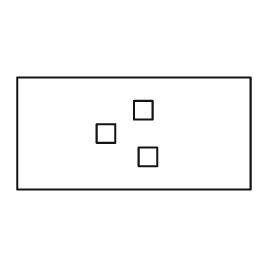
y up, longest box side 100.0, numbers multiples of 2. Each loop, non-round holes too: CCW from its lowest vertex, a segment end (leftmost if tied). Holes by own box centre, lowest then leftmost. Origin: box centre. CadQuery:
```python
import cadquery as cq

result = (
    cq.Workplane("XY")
    .moveTo(-50.0, -24.0)
    .lineTo(50.0, -24.0)
    .lineTo(50.0, 24.0)
    .lineTo(-50.0, 24.0)
    .close()
    .moveTo(2.0, -14.0)
    .lineTo(10.0, -14.0)
    .lineTo(10.0, -6.0)
    .lineTo(2.0, -6.0)
    .close()
    .moveTo(-16.0, -4.0)
    .lineTo(-8.0, -4.0)
    .lineTo(-8.0, 4.0)
    .lineTo(-16.0, 4.0)
    .close()
    .moveTo(0.0, 6.0)
    .lineTo(8.0, 6.0)
    .lineTo(8.0, 14.0)
    .lineTo(0.0, 14.0)
    .close()
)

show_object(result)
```